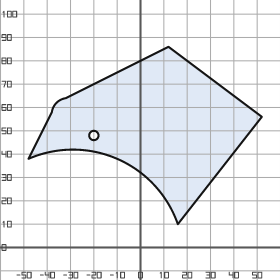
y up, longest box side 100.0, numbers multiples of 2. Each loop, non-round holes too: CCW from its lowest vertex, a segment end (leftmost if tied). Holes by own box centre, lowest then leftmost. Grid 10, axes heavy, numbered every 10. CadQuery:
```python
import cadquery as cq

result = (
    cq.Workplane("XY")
    .moveTo(16.0, 10.0)
    .lineTo(52.0, 56.0)
    .lineTo(12.0, 86.0)
    .lineTo(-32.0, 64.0)
    .threePointArc((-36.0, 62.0), (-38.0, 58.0))
    .lineTo(-48.0, 38.0)
    .threePointArc((-10.0, 38.0), (16.0, 10.0))
    .close()
    .moveTo(-20.0, 48.0)
    .circle(2.0)
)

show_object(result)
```